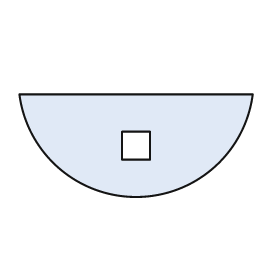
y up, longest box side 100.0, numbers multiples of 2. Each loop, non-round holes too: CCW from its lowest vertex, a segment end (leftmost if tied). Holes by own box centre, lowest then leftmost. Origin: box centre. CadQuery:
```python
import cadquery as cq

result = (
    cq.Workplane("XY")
    .moveTo(-50.0, 22.0)
    .threePointArc((0.0, -22.0), (50.0, 22.0))
    .close()
    .moveTo(-6.0, -6.0)
    .lineTo(6.0, -6.0)
    .lineTo(6.0, 6.0)
    .lineTo(-6.0, 6.0)
    .close()
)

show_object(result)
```